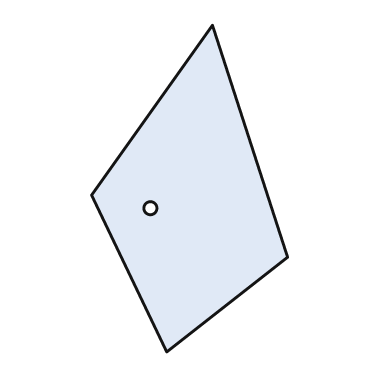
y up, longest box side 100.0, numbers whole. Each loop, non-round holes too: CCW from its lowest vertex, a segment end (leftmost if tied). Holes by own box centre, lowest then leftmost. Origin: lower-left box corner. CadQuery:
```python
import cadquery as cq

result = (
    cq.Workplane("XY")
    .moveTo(23.0, 0.0)
    .lineTo(60.0, 29.0)
    .lineTo(37.0, 100.0)
    .lineTo(0.0, 48.0)
    .close()
    .moveTo(18.0, 44.0)
    .circle(2.0)
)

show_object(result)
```